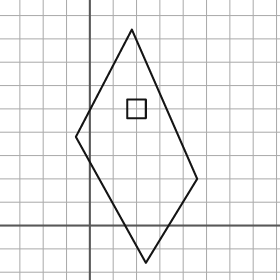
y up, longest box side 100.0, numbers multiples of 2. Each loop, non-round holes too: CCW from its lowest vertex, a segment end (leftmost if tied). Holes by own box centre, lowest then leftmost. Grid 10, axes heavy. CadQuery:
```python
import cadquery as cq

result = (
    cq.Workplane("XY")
    .moveTo(24.0, -16.0)
    .lineTo(46.0, 20.0)
    .lineTo(18.0, 84.0)
    .lineTo(-6.0, 38.0)
    .close()
    .moveTo(16.0, 46.0)
    .lineTo(24.0, 46.0)
    .lineTo(24.0, 54.0)
    .lineTo(16.0, 54.0)
    .close()
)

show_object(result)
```